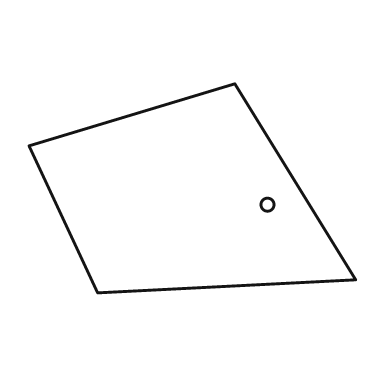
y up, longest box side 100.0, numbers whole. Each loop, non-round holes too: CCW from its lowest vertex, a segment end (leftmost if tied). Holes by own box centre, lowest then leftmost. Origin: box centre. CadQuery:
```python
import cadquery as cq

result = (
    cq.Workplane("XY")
    .moveTo(-29.0, -32.0)
    .lineTo(50.0, -28.0)
    .lineTo(13.0, 32.0)
    .lineTo(-50.0, 13.0)
    .close()
    .moveTo(23.0, -5.0)
    .circle(2.0)
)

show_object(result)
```